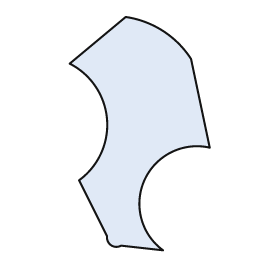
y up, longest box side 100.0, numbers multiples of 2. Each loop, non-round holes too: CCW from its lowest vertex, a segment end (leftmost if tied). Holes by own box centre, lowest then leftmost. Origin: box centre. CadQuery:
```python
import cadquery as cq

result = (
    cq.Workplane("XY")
    .moveTo(10.0, -50.0)
    .threePointArc((2.0, -20.0), (30.0, -6.0))
    .lineTo(22.0, 32.0)
    .threePointArc((10.0, 44.0), (-6.0, 50.0))
    .lineTo(-30.0, 30.0)
    .threePointArc((-14.0, 6.0), (-26.0, -20.0))
    .lineTo(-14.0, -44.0)
    .threePointArc((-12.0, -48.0), (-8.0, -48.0))
    .close()
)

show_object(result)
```